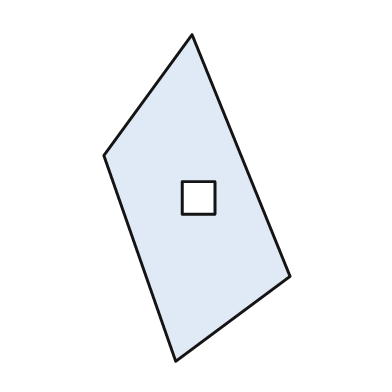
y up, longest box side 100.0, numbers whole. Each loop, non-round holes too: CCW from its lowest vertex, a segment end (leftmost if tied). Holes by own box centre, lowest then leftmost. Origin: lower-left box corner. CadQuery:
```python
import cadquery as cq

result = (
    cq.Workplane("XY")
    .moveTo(22.0, 0.0)
    .lineTo(57.0, 26.0)
    .lineTo(27.0, 100.0)
    .lineTo(0.0, 63.0)
    .close()
    .moveTo(24.0, 45.0)
    .lineTo(34.0, 45.0)
    .lineTo(34.0, 55.0)
    .lineTo(24.0, 55.0)
    .close()
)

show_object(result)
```